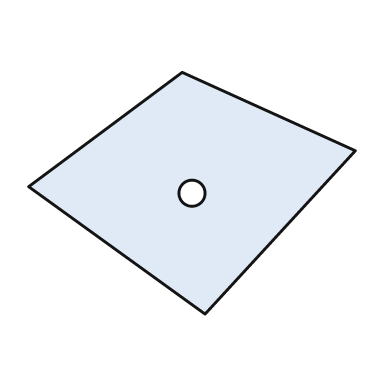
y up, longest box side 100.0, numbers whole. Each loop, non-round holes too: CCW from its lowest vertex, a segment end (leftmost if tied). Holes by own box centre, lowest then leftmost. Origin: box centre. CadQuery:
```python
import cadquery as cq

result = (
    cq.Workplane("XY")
    .moveTo(4.0, -37.0)
    .lineTo(50.0, 13.0)
    .lineTo(-3.0, 37.0)
    .lineTo(-50.0, 2.0)
    .close()
    .moveTo(0.0, 0.0)
    .circle(4.0)
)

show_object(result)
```